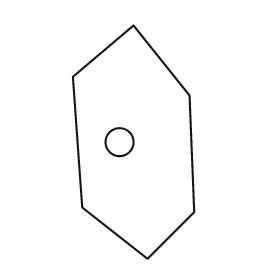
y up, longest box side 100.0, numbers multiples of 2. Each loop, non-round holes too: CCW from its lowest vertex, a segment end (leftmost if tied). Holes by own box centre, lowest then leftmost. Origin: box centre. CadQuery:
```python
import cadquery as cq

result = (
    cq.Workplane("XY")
    .moveTo(6.0, -50.0)
    .lineTo(26.0, -30.0)
    .lineTo(24.0, 20.0)
    .lineTo(0.0, 50.0)
    .lineTo(-26.0, 28.0)
    .lineTo(-22.0, -28.0)
    .close()
    .moveTo(-6.0, 0.0)
    .circle(6.0)
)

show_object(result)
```